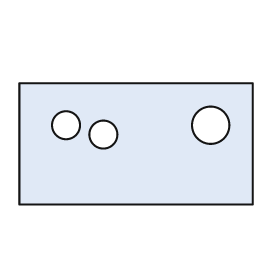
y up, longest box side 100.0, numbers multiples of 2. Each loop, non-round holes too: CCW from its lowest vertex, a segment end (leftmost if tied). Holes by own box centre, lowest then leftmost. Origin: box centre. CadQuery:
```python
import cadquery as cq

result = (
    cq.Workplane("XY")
    .moveTo(-50.0, -26.0)
    .lineTo(50.0, -26.0)
    .lineTo(50.0, 26.0)
    .lineTo(-50.0, 26.0)
    .close()
    .moveTo(-14.0, 4.0)
    .circle(6.0)
    .moveTo(-30.0, 8.0)
    .circle(6.0)
    .moveTo(32.0, 8.0)
    .circle(8.0)
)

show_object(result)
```